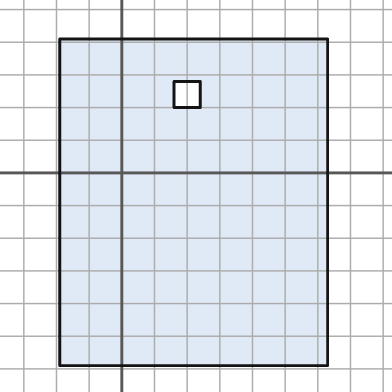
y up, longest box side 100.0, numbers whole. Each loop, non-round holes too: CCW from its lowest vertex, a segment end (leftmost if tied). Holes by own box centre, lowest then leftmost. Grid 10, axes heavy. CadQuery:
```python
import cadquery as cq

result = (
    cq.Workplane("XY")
    .moveTo(-19.0, -59.0)
    .lineTo(63.0, -59.0)
    .lineTo(63.0, 41.0)
    .lineTo(-19.0, 41.0)
    .close()
    .moveTo(16.0, 20.0)
    .lineTo(24.0, 20.0)
    .lineTo(24.0, 28.0)
    .lineTo(16.0, 28.0)
    .close()
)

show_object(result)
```